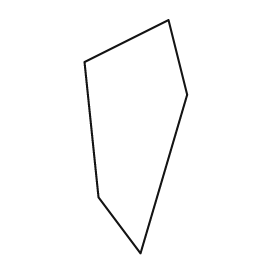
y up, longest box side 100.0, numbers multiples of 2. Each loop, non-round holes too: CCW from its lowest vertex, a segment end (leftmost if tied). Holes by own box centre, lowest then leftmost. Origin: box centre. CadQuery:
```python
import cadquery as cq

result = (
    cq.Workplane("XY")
    .moveTo(2.0, -50.0)
    .lineTo(22.0, 18.0)
    .lineTo(14.0, 50.0)
    .lineTo(-22.0, 32.0)
    .lineTo(-16.0, -26.0)
    .close()
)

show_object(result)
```